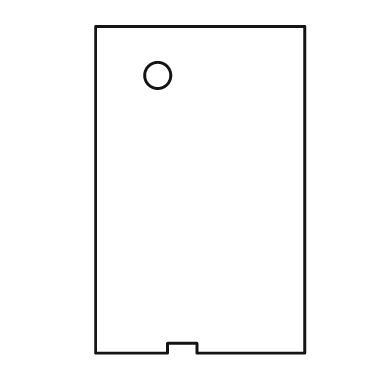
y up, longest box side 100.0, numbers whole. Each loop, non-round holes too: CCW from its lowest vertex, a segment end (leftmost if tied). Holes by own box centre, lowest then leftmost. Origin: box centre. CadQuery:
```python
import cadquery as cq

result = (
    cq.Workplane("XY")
    .moveTo(-32.0, -50.0)
    .lineTo(-10.0, -50.0)
    .lineTo(-10.0, -47.0)
    .lineTo(-1.0, -47.0)
    .lineTo(-1.0, -50.0)
    .lineTo(32.0, -50.0)
    .lineTo(32.0, 50.0)
    .lineTo(-32.0, 50.0)
    .close()
    .moveTo(-13.0, 35.0)
    .circle(4.0)
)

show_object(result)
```